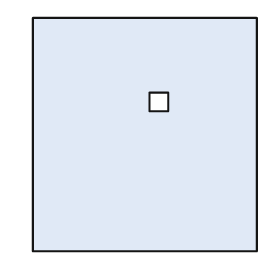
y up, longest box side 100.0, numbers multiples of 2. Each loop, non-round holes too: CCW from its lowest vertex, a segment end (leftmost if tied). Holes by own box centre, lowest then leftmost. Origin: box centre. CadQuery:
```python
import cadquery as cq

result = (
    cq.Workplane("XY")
    .moveTo(-48.0, -50.0)
    .lineTo(48.0, -50.0)
    .lineTo(48.0, 50.0)
    .lineTo(-48.0, 50.0)
    .close()
    .moveTo(2.0, 10.0)
    .lineTo(10.0, 10.0)
    .lineTo(10.0, 18.0)
    .lineTo(2.0, 18.0)
    .close()
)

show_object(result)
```